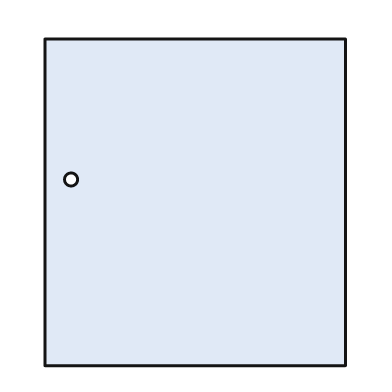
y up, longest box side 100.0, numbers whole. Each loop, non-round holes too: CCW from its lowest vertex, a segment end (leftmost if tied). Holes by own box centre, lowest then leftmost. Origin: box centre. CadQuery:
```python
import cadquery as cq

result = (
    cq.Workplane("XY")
    .moveTo(-46.0, -50.0)
    .lineTo(46.0, -50.0)
    .lineTo(46.0, 50.0)
    .lineTo(-46.0, 50.0)
    .close()
    .moveTo(-38.0, 7.0)
    .circle(2.0)
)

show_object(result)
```